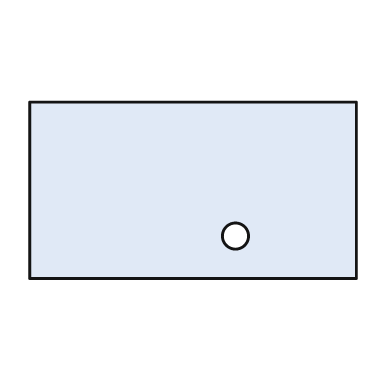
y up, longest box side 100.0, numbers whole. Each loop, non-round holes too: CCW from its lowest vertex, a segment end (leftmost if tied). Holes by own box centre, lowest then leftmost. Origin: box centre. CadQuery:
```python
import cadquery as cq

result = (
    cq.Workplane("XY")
    .moveTo(-50.0, -27.0)
    .lineTo(50.0, -27.0)
    .lineTo(50.0, 27.0)
    .lineTo(-50.0, 27.0)
    .close()
    .moveTo(13.0, -14.0)
    .circle(4.0)
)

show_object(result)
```